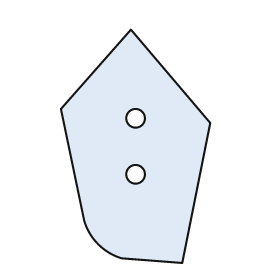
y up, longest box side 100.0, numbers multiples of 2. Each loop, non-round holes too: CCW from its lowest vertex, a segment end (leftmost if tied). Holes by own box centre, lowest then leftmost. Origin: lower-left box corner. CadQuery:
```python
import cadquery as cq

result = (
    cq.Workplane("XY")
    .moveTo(52.0, 0.0)
    .lineTo(64.0, 60.0)
    .lineTo(30.0, 100.0)
    .lineTo(0.0, 66.0)
    .lineTo(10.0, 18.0)
    .threePointArc((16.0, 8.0), (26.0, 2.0))
    .close()
    .moveTo(32.0, 38.0)
    .circle(4.0)
    .moveTo(32.0, 62.0)
    .circle(4.0)
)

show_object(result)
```